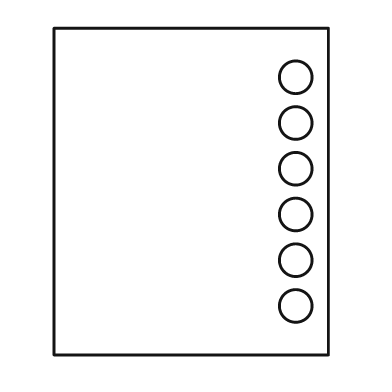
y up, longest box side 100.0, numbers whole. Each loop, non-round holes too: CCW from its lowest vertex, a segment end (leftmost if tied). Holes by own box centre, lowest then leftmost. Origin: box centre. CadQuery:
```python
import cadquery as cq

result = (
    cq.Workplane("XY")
    .moveTo(-42.0, -50.0)
    .lineTo(42.0, -50.0)
    .lineTo(42.0, 50.0)
    .lineTo(-42.0, 50.0)
    .close()
    .moveTo(32.0, -35.0)
    .circle(5.0)
    .moveTo(32.0, -21.0)
    .circle(5.0)
    .moveTo(32.0, -7.0)
    .circle(5.0)
    .moveTo(32.0, 7.0)
    .circle(5.0)
    .moveTo(32.0, 21.0)
    .circle(5.0)
    .moveTo(32.0, 35.0)
    .circle(5.0)
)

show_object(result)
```